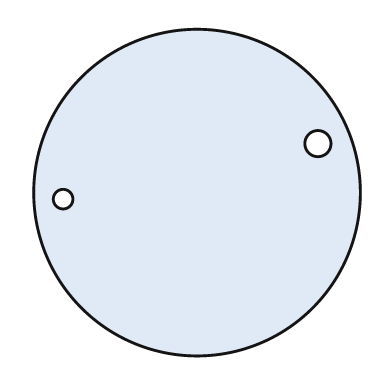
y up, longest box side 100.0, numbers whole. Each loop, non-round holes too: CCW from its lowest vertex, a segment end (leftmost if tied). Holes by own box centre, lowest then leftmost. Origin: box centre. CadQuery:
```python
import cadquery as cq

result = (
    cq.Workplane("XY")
    .moveTo(0.0, 0.0)
    .circle(50.0)
    .moveTo(-41.0, -2.0)
    .circle(3.0)
    .moveTo(37.0, 15.0)
    .circle(4.0)
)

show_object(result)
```